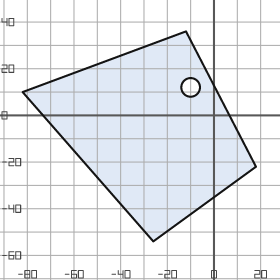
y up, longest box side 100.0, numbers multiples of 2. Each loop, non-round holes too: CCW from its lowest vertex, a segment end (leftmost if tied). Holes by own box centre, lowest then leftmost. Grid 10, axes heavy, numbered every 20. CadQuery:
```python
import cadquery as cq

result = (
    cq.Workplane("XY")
    .moveTo(-26.0, -54.0)
    .lineTo(18.0, -22.0)
    .lineTo(-12.0, 36.0)
    .lineTo(-82.0, 10.0)
    .close()
    .moveTo(-10.0, 12.0)
    .circle(4.0)
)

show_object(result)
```